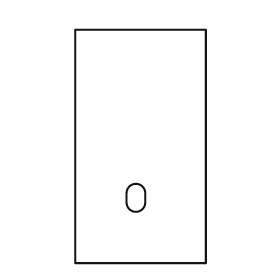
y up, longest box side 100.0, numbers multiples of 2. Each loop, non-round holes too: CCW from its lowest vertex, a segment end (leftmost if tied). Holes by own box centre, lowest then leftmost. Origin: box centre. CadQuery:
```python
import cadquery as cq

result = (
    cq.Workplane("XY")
    .moveTo(-28.0, -50.0)
    .lineTo(28.0, -50.0)
    .lineTo(28.0, 50.0)
    .lineTo(-28.0, 50.0)
    .close()
    .moveTo(-6.0, -24.0)
    .threePointArc((-2.0, -28.0), (2.0, -24.0))
    .lineTo(2.0, -20.0)
    .threePointArc((-2.0, -16.0), (-6.0, -20.0))
    .close()
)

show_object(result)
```